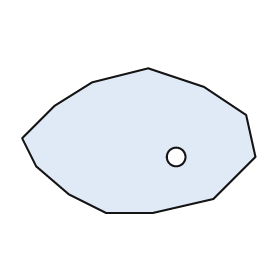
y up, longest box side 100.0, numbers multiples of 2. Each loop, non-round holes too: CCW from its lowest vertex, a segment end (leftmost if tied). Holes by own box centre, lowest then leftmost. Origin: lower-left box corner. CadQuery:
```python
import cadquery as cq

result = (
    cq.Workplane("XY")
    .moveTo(36.0, 0.0)
    .lineTo(56.0, 0.0)
    .lineTo(82.0, 6.0)
    .lineTo(100.0, 24.0)
    .lineTo(96.0, 42.0)
    .lineTo(78.0, 54.0)
    .lineTo(54.0, 62.0)
    .lineTo(30.0, 56.0)
    .lineTo(14.0, 46.0)
    .lineTo(0.0, 32.0)
    .lineTo(6.0, 20.0)
    .lineTo(20.0, 8.0)
    .close()
    .moveTo(66.0, 24.0)
    .circle(4.0)
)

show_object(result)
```